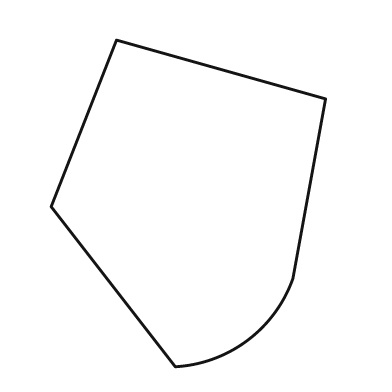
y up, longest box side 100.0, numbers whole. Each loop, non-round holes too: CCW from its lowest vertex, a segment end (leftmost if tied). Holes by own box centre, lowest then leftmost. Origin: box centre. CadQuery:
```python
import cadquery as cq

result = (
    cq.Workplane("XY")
    .moveTo(-4.0, -50.0)
    .threePointArc((18.0, -42.0), (32.0, -23.0))
    .lineTo(42.0, 32.0)
    .lineTo(-22.0, 50.0)
    .lineTo(-42.0, -1.0)
    .close()
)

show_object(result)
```